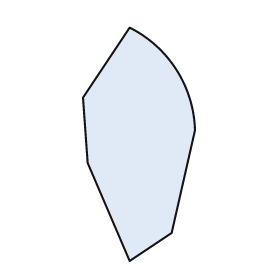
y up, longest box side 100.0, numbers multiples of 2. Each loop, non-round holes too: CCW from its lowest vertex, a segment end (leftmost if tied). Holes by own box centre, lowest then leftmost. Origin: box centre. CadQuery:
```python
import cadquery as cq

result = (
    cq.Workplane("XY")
    .moveTo(-4.0, -50.0)
    .lineTo(14.0, -38.0)
    .lineTo(24.0, 6.0)
    .threePointArc((16.0, 32.0), (-4.0, 50.0))
    .lineTo(-24.0, 20.0)
    .lineTo(-22.0, -8.0)
    .close()
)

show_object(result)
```